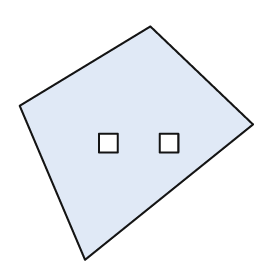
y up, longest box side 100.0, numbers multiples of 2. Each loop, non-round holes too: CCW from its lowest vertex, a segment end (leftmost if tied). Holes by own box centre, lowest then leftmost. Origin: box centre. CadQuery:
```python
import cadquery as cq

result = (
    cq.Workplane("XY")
    .moveTo(-22.0, -50.0)
    .lineTo(50.0, 8.0)
    .lineTo(6.0, 50.0)
    .lineTo(-50.0, 16.0)
    .close()
    .moveTo(-16.0, -4.0)
    .lineTo(-8.0, -4.0)
    .lineTo(-8.0, 4.0)
    .lineTo(-16.0, 4.0)
    .close()
    .moveTo(10.0, -4.0)
    .lineTo(18.0, -4.0)
    .lineTo(18.0, 4.0)
    .lineTo(10.0, 4.0)
    .close()
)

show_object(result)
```